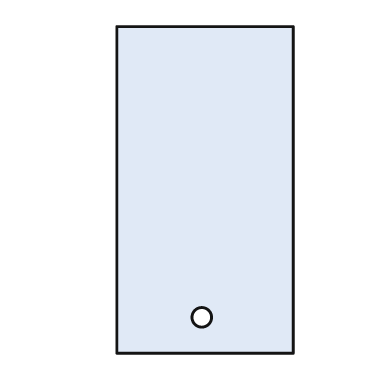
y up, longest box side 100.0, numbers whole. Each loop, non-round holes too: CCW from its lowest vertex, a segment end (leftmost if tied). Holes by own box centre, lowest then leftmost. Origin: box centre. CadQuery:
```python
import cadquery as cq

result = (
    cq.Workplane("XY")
    .moveTo(-27.0, -50.0)
    .lineTo(27.0, -50.0)
    .lineTo(27.0, 50.0)
    .lineTo(-27.0, 50.0)
    .close()
    .moveTo(-1.0, -39.0)
    .circle(3.0)
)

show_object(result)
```